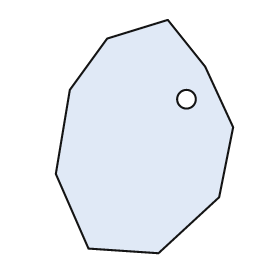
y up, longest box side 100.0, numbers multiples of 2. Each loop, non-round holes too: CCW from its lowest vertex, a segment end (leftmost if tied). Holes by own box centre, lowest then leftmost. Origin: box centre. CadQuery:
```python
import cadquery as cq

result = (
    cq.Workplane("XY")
    .moveTo(6.0, -50.0)
    .lineTo(32.0, -26.0)
    .lineTo(38.0, 4.0)
    .lineTo(26.0, 30.0)
    .lineTo(10.0, 50.0)
    .lineTo(-16.0, 42.0)
    .lineTo(-32.0, 20.0)
    .lineTo(-38.0, -16.0)
    .lineTo(-24.0, -48.0)
    .close()
    .moveTo(18.0, 16.0)
    .circle(4.0)
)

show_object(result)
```